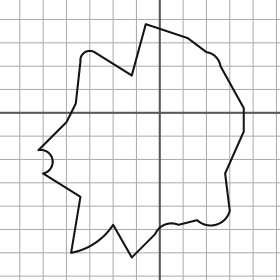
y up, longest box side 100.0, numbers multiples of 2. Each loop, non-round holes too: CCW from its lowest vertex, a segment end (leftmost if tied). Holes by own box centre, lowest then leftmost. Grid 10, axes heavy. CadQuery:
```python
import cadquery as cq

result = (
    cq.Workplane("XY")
    .moveTo(-12.0, -62.0)
    .lineTo(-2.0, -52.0)
    .threePointArc((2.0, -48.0), (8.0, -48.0))
    .lineTo(16.0, -46.0)
    .threePointArc((24.0, -48.0), (30.0, -42.0))
    .lineTo(28.0, -26.0)
    .lineTo(36.0, -8.0)
    .lineTo(36.0, 2.0)
    .lineTo(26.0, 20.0)
    .threePointArc((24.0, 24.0), (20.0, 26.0))
    .lineTo(12.0, 32.0)
    .lineTo(-6.0, 38.0)
    .lineTo(-12.0, 16.0)
    .lineTo(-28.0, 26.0)
    .threePointArc((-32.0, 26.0), (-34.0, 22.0))
    .lineTo(-36.0, 4.0)
    .lineTo(-40.0, -4.0)
    .lineTo(-52.0, -16.0)
    .threePointArc((-46.0, -20.0), (-50.0, -26.0))
    .lineTo(-34.0, -36.0)
    .lineTo(-38.0, -60.0)
    .threePointArc((-28.0, -56.0), (-20.0, -48.0))
    .close()
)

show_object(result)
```